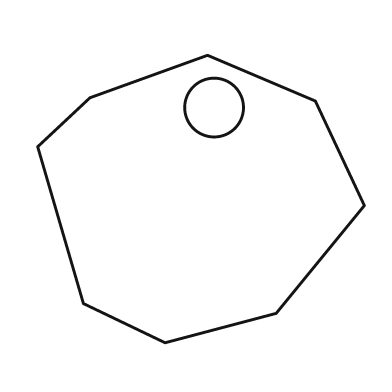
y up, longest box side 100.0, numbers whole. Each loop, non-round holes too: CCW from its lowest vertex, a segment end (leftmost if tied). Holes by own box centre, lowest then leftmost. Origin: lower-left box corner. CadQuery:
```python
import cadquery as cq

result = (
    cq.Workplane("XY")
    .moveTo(39.0, 0.0)
    .lineTo(73.0, 9.0)
    .lineTo(100.0, 42.0)
    .lineTo(85.0, 74.0)
    .lineTo(52.0, 88.0)
    .lineTo(16.0, 75.0)
    .lineTo(0.0, 60.0)
    .lineTo(14.0, 12.0)
    .close()
    .moveTo(54.0, 72.0)
    .circle(9.0)
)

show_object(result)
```